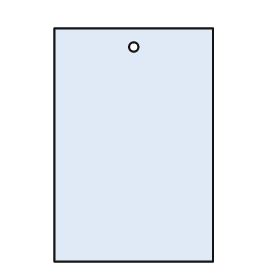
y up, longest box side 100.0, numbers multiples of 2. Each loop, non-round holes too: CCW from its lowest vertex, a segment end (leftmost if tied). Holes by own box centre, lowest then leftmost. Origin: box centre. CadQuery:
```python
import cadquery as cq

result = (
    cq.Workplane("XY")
    .moveTo(-34.0, -50.0)
    .lineTo(34.0, -50.0)
    .lineTo(34.0, 50.0)
    .lineTo(-34.0, 50.0)
    .close()
    .moveTo(0.0, 42.0)
    .circle(2.0)
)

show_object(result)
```